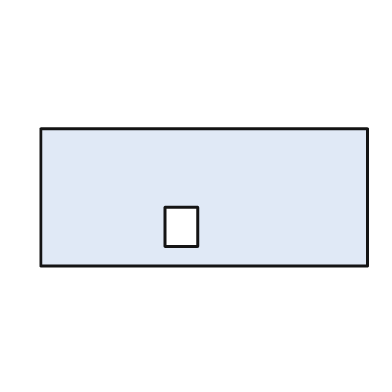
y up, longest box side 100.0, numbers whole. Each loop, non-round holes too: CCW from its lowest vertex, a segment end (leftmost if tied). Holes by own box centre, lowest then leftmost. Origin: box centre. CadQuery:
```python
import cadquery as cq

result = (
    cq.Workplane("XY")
    .moveTo(-50.0, -21.0)
    .lineTo(50.0, -21.0)
    .lineTo(50.0, 21.0)
    .lineTo(-50.0, 21.0)
    .close()
    .moveTo(-12.0, -15.0)
    .lineTo(-2.0, -15.0)
    .lineTo(-2.0, -3.0)
    .lineTo(-12.0, -3.0)
    .close()
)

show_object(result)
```